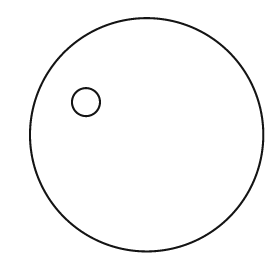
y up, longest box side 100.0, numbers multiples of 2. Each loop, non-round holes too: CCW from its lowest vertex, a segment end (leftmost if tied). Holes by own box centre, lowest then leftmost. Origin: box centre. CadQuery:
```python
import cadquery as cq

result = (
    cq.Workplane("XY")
    .moveTo(0.0, 0.0)
    .circle(50.0)
    .moveTo(-26.0, 14.0)
    .circle(6.0)
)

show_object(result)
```